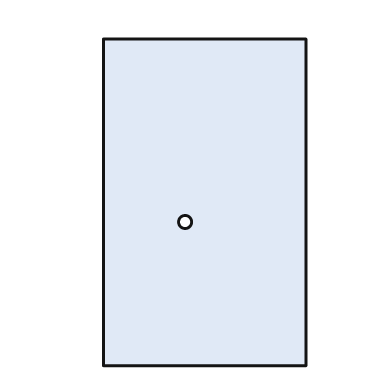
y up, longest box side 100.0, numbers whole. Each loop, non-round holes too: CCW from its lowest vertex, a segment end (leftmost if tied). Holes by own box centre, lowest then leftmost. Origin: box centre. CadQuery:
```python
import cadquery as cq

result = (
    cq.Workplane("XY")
    .moveTo(-31.0, -50.0)
    .lineTo(31.0, -50.0)
    .lineTo(31.0, 50.0)
    .lineTo(-31.0, 50.0)
    .close()
    .moveTo(-6.0, -6.0)
    .circle(2.0)
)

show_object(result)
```